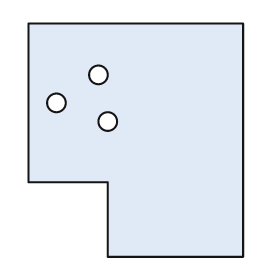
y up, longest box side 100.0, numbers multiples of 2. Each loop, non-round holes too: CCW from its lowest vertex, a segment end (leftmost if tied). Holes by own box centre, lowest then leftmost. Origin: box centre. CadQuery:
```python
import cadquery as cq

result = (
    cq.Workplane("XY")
    .moveTo(-12.0, -50.0)
    .lineTo(46.0, -50.0)
    .lineTo(46.0, 50.0)
    .lineTo(-46.0, 50.0)
    .lineTo(-46.0, -18.0)
    .lineTo(-12.0, -18.0)
    .close()
    .moveTo(-12.0, 8.0)
    .circle(4.0)
    .moveTo(-34.0, 16.0)
    .circle(4.0)
    .moveTo(-16.0, 28.0)
    .circle(4.0)
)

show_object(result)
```